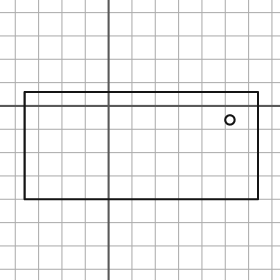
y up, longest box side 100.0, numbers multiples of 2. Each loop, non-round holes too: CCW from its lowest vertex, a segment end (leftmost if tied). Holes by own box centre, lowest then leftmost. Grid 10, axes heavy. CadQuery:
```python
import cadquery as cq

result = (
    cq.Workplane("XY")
    .moveTo(-36.0, -40.0)
    .lineTo(64.0, -40.0)
    .lineTo(64.0, 6.0)
    .lineTo(-36.0, 6.0)
    .close()
    .moveTo(52.0, -6.0)
    .circle(2.0)
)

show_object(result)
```